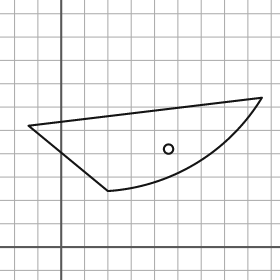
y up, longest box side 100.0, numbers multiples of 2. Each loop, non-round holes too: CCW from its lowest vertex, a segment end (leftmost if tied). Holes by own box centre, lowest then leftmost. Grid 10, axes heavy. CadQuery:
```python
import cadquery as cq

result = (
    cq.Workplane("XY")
    .moveTo(20.0, 24.0)
    .threePointArc((58.0, 36.0), (86.0, 64.0))
    .lineTo(-14.0, 52.0)
    .close()
    .moveTo(46.0, 42.0)
    .circle(2.0)
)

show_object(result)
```